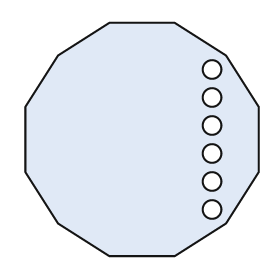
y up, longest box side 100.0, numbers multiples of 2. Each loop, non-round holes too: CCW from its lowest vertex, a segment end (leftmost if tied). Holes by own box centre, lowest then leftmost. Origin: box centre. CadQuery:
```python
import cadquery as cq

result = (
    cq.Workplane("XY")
    .moveTo(-14.0, -50.0)
    .lineTo(14.0, -50.0)
    .lineTo(36.0, -36.0)
    .lineTo(50.0, -14.0)
    .lineTo(50.0, 14.0)
    .lineTo(36.0, 36.0)
    .lineTo(14.0, 50.0)
    .lineTo(-14.0, 50.0)
    .lineTo(-36.0, 36.0)
    .lineTo(-50.0, 14.0)
    .lineTo(-50.0, -14.0)
    .lineTo(-36.0, -36.0)
    .close()
    .moveTo(30.0, -30.0)
    .circle(4.0)
    .moveTo(30.0, -18.0)
    .circle(4.0)
    .moveTo(30.0, -6.0)
    .circle(4.0)
    .moveTo(30.0, 6.0)
    .circle(4.0)
    .moveTo(30.0, 18.0)
    .circle(4.0)
    .moveTo(30.0, 30.0)
    .circle(4.0)
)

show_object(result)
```